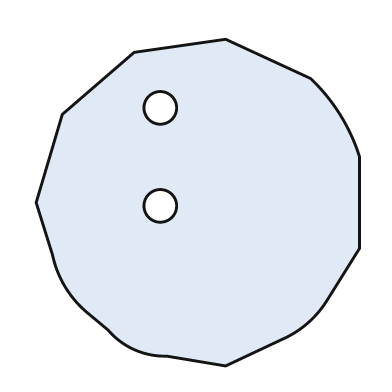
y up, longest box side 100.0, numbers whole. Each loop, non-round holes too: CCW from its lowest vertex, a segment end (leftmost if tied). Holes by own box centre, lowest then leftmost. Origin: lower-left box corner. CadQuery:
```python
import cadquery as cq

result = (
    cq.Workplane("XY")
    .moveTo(58.0, 0.0)
    .lineTo(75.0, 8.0)
    .threePointArc((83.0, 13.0), (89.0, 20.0))
    .lineTo(99.0, 36.0)
    .lineTo(99.0, 64.0)
    .threePointArc((93.0, 77.0), (84.0, 88.0))
    .lineTo(58.0, 100.0)
    .lineTo(30.0, 96.0)
    .lineTo(8.0, 77.0)
    .lineTo(0.0, 50.0)
    .lineTo(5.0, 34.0)
    .threePointArc((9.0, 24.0), (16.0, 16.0))
    .lineTo(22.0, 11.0)
    .threePointArc((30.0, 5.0), (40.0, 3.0))
    .close()
    .moveTo(38.0, 49.0)
    .circle(5.0)
    .moveTo(38.0, 79.0)
    .circle(5.0)
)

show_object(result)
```